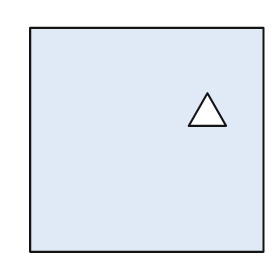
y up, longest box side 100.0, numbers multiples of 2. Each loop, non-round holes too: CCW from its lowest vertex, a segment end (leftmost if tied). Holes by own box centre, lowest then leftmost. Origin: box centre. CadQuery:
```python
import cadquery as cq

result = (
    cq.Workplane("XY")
    .moveTo(-50.0, -48.0)
    .lineTo(50.0, -48.0)
    .lineTo(50.0, 48.0)
    .lineTo(-50.0, 48.0)
    .close()
    .moveTo(18.0, 6.0)
    .lineTo(34.0, 6.0)
    .lineTo(26.0, 20.0)
    .close()
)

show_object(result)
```